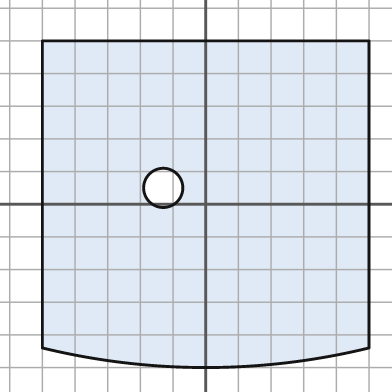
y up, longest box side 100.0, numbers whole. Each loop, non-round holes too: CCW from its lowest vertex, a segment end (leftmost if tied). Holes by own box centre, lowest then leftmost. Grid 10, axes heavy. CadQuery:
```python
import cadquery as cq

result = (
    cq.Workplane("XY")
    .moveTo(-50.0, -44.0)
    .threePointArc((0.0, -50.0), (50.0, -44.0))
    .lineTo(50.0, 50.0)
    .lineTo(-50.0, 50.0)
    .close()
    .moveTo(-13.0, 5.0)
    .circle(6.0)
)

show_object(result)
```